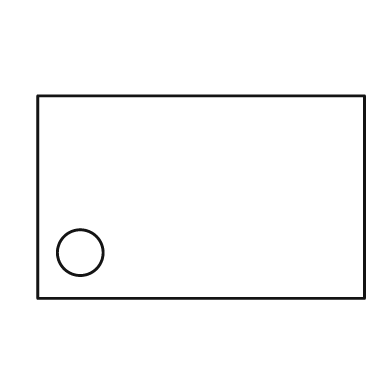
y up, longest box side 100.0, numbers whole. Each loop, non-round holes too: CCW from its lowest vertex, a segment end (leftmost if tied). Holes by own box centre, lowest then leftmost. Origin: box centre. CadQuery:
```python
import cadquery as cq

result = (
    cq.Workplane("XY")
    .moveTo(-50.0, -31.0)
    .lineTo(50.0, -31.0)
    .lineTo(50.0, 31.0)
    .lineTo(-50.0, 31.0)
    .close()
    .moveTo(-37.0, -17.0)
    .circle(7.0)
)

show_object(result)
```